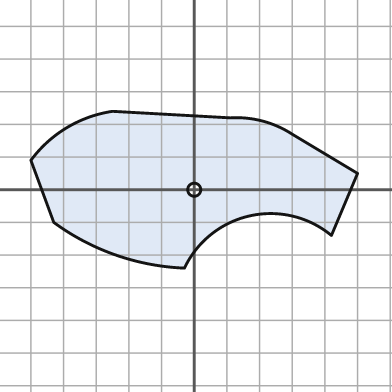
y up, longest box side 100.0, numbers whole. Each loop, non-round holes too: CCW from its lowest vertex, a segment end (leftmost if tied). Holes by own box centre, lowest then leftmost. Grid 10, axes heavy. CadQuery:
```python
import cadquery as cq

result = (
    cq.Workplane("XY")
    .moveTo(-3.0, -24.0)
    .threePointArc((17.0, -8.0), (42.0, -14.0))
    .lineTo(50.0, 5.0)
    .lineTo(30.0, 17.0)
    .threePointArc((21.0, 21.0), (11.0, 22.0))
    .lineTo(-25.0, 24.0)
    .threePointArc((-39.0, 19.0), (-50.0, 9.0))
    .lineTo(-43.0, -10.0)
    .threePointArc((-24.0, -20.0), (-3.0, -24.0))
    .close()
    .moveTo(0.0, 0.0)
    .circle(2.0)
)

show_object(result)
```